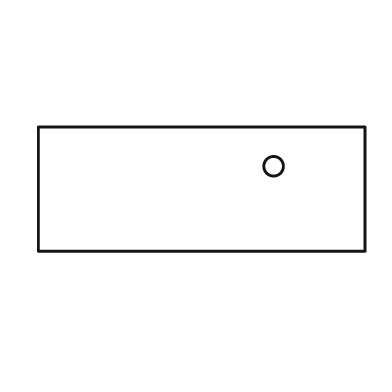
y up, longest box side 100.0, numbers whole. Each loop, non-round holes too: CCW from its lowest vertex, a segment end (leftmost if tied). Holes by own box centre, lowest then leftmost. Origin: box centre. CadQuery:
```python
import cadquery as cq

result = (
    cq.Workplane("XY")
    .moveTo(-50.0, -19.0)
    .lineTo(50.0, -19.0)
    .lineTo(50.0, 19.0)
    .lineTo(-50.0, 19.0)
    .close()
    .moveTo(22.0, 7.0)
    .circle(3.0)
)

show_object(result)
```